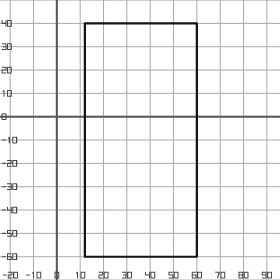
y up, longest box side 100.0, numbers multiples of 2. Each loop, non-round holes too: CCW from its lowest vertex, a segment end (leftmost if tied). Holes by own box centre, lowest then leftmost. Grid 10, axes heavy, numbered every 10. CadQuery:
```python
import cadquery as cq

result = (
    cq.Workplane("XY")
    .moveTo(12.0, -60.0)
    .lineTo(60.0, -60.0)
    .lineTo(60.0, 40.0)
    .lineTo(12.0, 40.0)
    .close()
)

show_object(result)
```